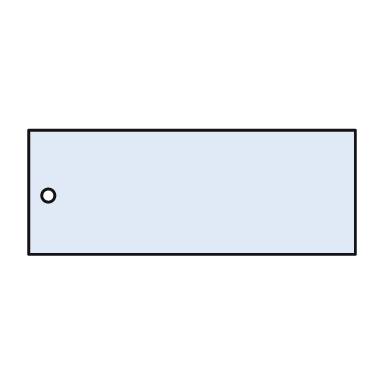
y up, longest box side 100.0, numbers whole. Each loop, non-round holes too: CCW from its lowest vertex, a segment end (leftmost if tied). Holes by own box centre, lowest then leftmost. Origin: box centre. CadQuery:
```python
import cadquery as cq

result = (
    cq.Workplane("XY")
    .moveTo(-50.0, -19.0)
    .lineTo(50.0, -19.0)
    .lineTo(50.0, 19.0)
    .lineTo(-50.0, 19.0)
    .close()
    .moveTo(-44.0, -1.0)
    .circle(2.0)
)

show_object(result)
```